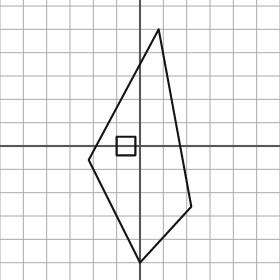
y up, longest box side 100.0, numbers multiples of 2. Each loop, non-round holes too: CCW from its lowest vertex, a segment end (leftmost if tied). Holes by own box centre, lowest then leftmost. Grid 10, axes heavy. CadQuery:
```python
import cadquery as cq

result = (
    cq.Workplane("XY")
    .moveTo(0.0, -50.0)
    .lineTo(22.0, -26.0)
    .lineTo(8.0, 50.0)
    .lineTo(-22.0, -6.0)
    .close()
    .moveTo(-10.0, -4.0)
    .lineTo(-2.0, -4.0)
    .lineTo(-2.0, 4.0)
    .lineTo(-10.0, 4.0)
    .close()
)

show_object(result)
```